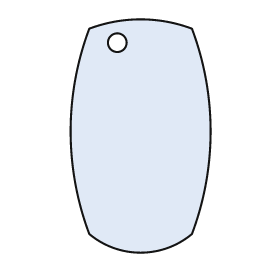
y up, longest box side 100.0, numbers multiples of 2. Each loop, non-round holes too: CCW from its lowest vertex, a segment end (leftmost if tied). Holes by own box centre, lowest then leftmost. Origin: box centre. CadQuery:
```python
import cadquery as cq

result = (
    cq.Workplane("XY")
    .moveTo(-22.0, -42.0)
    .threePointArc((0.0, -50.0), (22.0, -42.0))
    .threePointArc((30.0, 2.0), (22.0, 46.0))
    .threePointArc((0.0, 50.0), (-22.0, 46.0))
    .threePointArc((-30.0, 2.0), (-22.0, -42.0))
    .close()
    .moveTo(-10.0, 40.0)
    .circle(4.0)
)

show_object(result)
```